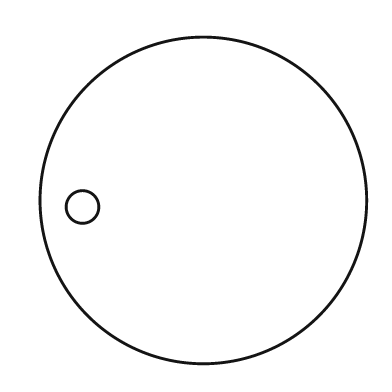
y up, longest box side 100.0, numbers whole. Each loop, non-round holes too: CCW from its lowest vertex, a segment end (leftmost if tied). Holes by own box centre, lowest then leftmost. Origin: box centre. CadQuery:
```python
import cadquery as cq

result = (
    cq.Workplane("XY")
    .moveTo(0.0, 0.0)
    .circle(50.0)
    .moveTo(-37.0, -2.0)
    .circle(5.0)
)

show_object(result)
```